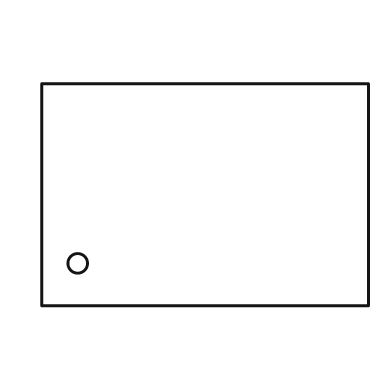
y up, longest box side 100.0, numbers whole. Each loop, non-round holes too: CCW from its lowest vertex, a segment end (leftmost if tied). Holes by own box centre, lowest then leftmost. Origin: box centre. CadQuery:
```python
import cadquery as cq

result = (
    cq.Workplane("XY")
    .moveTo(-50.0, -34.0)
    .lineTo(50.0, -34.0)
    .lineTo(50.0, 34.0)
    .lineTo(-50.0, 34.0)
    .close()
    .moveTo(-39.0, -21.0)
    .circle(3.0)
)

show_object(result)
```